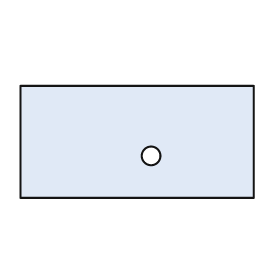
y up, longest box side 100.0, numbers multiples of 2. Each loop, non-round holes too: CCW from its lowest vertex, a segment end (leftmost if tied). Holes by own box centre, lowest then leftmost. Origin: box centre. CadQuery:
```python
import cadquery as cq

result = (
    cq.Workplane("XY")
    .moveTo(-50.0, -24.0)
    .lineTo(50.0, -24.0)
    .lineTo(50.0, 24.0)
    .lineTo(-50.0, 24.0)
    .close()
    .moveTo(6.0, -6.0)
    .circle(4.0)
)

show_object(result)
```